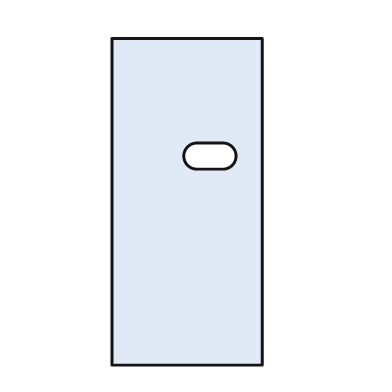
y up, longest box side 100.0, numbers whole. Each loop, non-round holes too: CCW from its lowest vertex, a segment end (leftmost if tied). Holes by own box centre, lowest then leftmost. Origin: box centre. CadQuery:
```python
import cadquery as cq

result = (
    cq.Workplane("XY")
    .moveTo(-23.0, -50.0)
    .lineTo(23.0, -50.0)
    .lineTo(23.0, 50.0)
    .lineTo(-23.0, 50.0)
    .close()
    .moveTo(3.0, 10.0)
    .lineTo(11.0, 10.0)
    .threePointArc((15.0, 14.0), (11.0, 18.0))
    .lineTo(3.0, 18.0)
    .threePointArc((-1.0, 14.0), (3.0, 10.0))
    .close()
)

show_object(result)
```